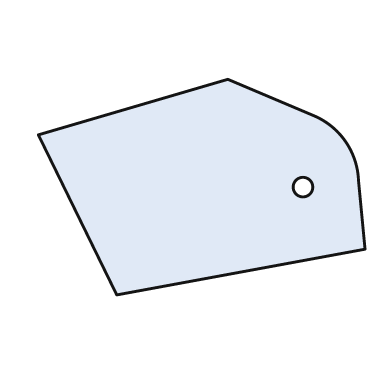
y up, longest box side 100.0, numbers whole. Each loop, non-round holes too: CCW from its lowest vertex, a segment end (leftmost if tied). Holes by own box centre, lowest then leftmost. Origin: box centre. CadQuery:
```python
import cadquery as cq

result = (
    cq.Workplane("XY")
    .moveTo(-26.0, -33.0)
    .lineTo(50.0, -19.0)
    .lineTo(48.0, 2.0)
    .threePointArc((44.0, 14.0), (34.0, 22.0))
    .lineTo(8.0, 33.0)
    .lineTo(-50.0, 16.0)
    .close()
    .moveTo(31.0, 0.0)
    .circle(3.0)
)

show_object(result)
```